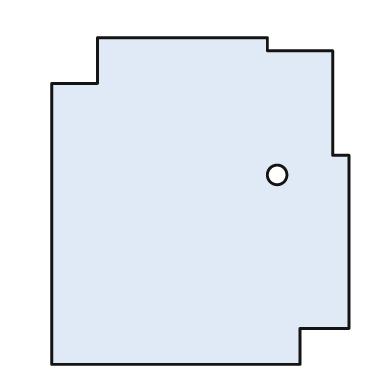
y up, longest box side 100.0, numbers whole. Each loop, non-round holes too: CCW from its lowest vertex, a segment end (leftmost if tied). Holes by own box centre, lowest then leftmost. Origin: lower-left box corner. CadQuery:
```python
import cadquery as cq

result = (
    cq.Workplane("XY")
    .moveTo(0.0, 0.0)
    .lineTo(76.0, 0.0)
    .lineTo(76.0, 11.0)
    .lineTo(91.0, 11.0)
    .lineTo(91.0, 64.0)
    .lineTo(86.0, 64.0)
    .lineTo(86.0, 96.0)
    .lineTo(66.0, 96.0)
    .lineTo(66.0, 100.0)
    .lineTo(14.0, 100.0)
    .lineTo(14.0, 86.0)
    .lineTo(0.0, 86.0)
    .close()
    .moveTo(69.0, 58.0)
    .circle(3.0)
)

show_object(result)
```